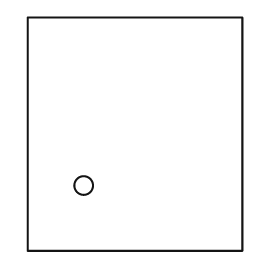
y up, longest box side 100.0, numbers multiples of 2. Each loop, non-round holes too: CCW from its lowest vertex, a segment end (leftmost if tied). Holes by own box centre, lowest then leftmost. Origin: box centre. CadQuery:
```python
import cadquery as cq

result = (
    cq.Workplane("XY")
    .moveTo(-46.0, -50.0)
    .lineTo(46.0, -50.0)
    .lineTo(46.0, 50.0)
    .lineTo(-46.0, 50.0)
    .close()
    .moveTo(-22.0, -22.0)
    .circle(4.0)
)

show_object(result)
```